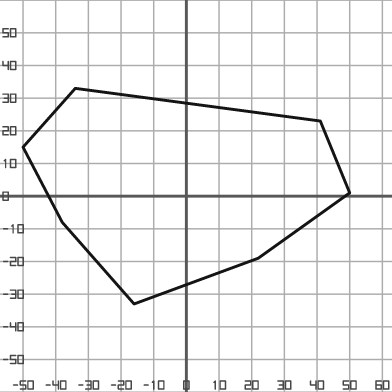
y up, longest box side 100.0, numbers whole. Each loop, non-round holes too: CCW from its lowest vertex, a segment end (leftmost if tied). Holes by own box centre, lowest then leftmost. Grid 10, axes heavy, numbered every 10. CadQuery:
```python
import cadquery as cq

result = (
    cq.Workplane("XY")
    .moveTo(-16.0, -33.0)
    .lineTo(22.0, -19.0)
    .lineTo(50.0, 1.0)
    .lineTo(41.0, 23.0)
    .lineTo(-34.0, 33.0)
    .lineTo(-50.0, 15.0)
    .lineTo(-38.0, -8.0)
    .close()
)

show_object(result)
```